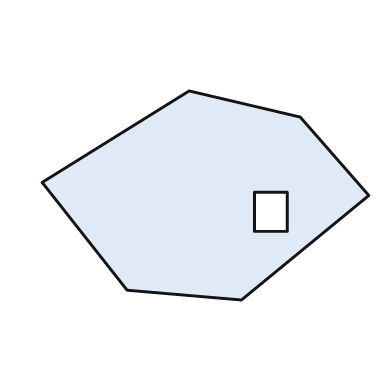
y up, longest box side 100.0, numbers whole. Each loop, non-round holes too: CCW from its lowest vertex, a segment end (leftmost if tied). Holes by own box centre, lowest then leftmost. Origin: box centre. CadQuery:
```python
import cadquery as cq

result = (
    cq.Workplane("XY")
    .moveTo(11.0, -32.0)
    .lineTo(50.0, 0.0)
    .lineTo(29.0, 24.0)
    .lineTo(-5.0, 32.0)
    .lineTo(-50.0, 4.0)
    .lineTo(-24.0, -29.0)
    .close()
    .moveTo(15.0, -11.0)
    .lineTo(25.0, -11.0)
    .lineTo(25.0, 1.0)
    .lineTo(15.0, 1.0)
    .close()
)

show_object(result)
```